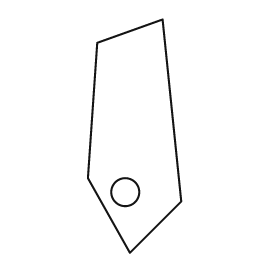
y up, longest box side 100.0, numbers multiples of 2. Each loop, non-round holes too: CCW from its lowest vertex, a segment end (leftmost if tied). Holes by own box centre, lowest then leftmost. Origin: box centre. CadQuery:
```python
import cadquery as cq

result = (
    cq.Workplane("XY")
    .moveTo(-2.0, -50.0)
    .lineTo(20.0, -28.0)
    .lineTo(12.0, 50.0)
    .lineTo(-16.0, 40.0)
    .lineTo(-20.0, -18.0)
    .close()
    .moveTo(-4.0, -24.0)
    .circle(6.0)
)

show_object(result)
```